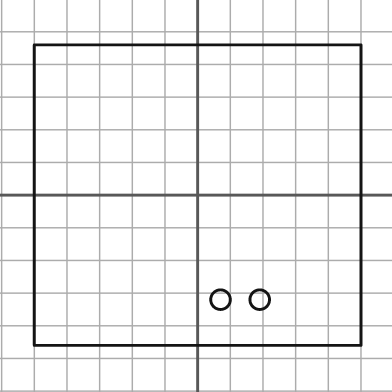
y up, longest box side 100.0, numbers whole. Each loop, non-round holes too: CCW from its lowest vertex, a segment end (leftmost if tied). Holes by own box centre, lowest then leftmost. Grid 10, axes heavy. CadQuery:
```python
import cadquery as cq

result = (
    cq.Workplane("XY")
    .moveTo(-50.0, -46.0)
    .lineTo(50.0, -46.0)
    .lineTo(50.0, 46.0)
    .lineTo(-50.0, 46.0)
    .close()
    .moveTo(7.0, -32.0)
    .circle(3.0)
    .moveTo(19.0, -32.0)
    .circle(3.0)
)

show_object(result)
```